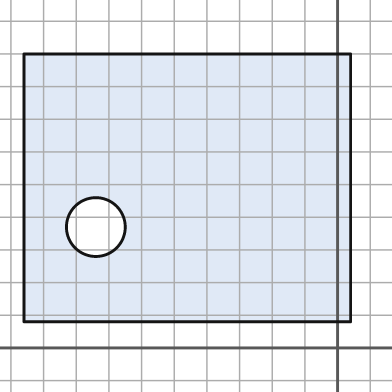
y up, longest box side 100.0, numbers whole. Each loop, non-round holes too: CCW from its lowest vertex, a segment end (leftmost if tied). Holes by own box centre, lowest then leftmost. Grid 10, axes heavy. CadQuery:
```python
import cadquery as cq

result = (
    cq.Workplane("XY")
    .moveTo(-96.0, 8.0)
    .lineTo(4.0, 8.0)
    .lineTo(4.0, 90.0)
    .lineTo(-96.0, 90.0)
    .close()
    .moveTo(-74.0, 37.0)
    .circle(9.0)
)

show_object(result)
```